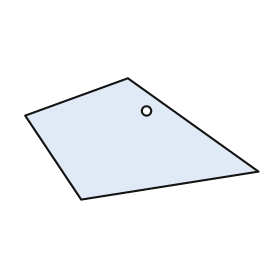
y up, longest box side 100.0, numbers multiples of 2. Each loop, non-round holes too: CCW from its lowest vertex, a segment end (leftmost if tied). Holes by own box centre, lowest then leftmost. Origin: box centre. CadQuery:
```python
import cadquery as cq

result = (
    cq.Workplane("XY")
    .moveTo(-26.0, -26.0)
    .lineTo(50.0, -14.0)
    .lineTo(-6.0, 26.0)
    .lineTo(-50.0, 10.0)
    .close()
    .moveTo(2.0, 12.0)
    .circle(2.0)
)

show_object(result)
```